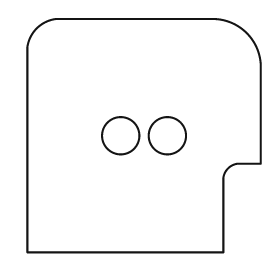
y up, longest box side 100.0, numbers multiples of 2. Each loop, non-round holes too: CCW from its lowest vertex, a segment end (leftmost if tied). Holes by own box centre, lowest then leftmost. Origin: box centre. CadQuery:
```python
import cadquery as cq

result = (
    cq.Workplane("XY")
    .moveTo(-50.0, -50.0)
    .lineTo(34.0, -50.0)
    .lineTo(34.0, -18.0)
    .threePointArc((36.0, -14.0), (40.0, -12.0))
    .lineTo(50.0, -12.0)
    .lineTo(50.0, 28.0)
    .threePointArc((44.0, 44.0), (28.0, 50.0))
    .lineTo(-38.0, 50.0)
    .threePointArc((-46.0, 46.0), (-50.0, 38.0))
    .close()
    .moveTo(-10.0, 0.0)
    .circle(8.0)
    .moveTo(10.0, 0.0)
    .circle(8.0)
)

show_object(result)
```